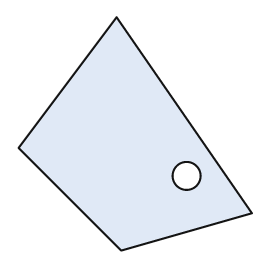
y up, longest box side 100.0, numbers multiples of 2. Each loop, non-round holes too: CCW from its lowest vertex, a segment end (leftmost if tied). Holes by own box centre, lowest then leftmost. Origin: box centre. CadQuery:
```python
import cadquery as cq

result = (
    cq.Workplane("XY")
    .moveTo(-6.0, -50.0)
    .lineTo(50.0, -34.0)
    .lineTo(-8.0, 50.0)
    .lineTo(-50.0, -6.0)
    .close()
    .moveTo(22.0, -18.0)
    .circle(6.0)
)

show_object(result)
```